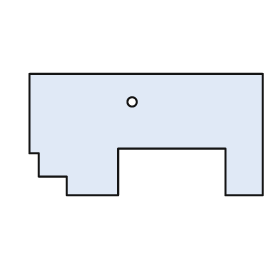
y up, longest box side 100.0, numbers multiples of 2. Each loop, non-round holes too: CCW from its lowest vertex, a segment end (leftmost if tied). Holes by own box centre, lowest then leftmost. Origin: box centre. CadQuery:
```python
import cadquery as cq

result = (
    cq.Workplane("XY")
    .moveTo(-34.0, -26.0)
    .lineTo(-12.0, -26.0)
    .lineTo(-12.0, -6.0)
    .lineTo(34.0, -6.0)
    .lineTo(34.0, -26.0)
    .lineTo(50.0, -26.0)
    .lineTo(50.0, 26.0)
    .lineTo(-50.0, 26.0)
    .lineTo(-50.0, -8.0)
    .lineTo(-46.0, -8.0)
    .lineTo(-46.0, -18.0)
    .lineTo(-34.0, -18.0)
    .close()
    .moveTo(-6.0, 14.0)
    .circle(2.0)
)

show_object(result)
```